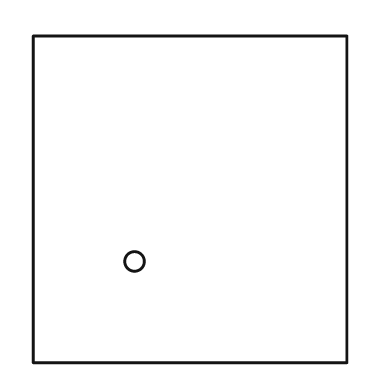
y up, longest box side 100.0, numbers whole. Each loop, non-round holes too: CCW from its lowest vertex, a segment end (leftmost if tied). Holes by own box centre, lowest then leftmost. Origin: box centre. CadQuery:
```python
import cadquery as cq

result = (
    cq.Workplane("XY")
    .moveTo(-48.0, -50.0)
    .lineTo(48.0, -50.0)
    .lineTo(48.0, 50.0)
    .lineTo(-48.0, 50.0)
    .close()
    .moveTo(-17.0, -19.0)
    .circle(3.0)
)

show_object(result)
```